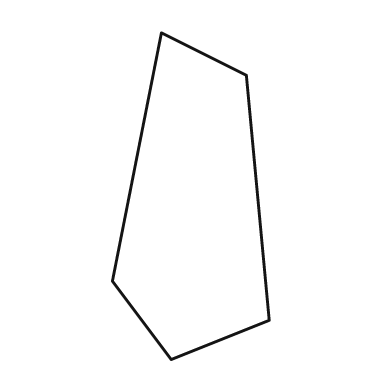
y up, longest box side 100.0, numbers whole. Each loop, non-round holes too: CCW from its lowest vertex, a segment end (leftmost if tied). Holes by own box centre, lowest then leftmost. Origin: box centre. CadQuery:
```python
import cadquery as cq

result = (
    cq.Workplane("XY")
    .moveTo(-6.0, -50.0)
    .lineTo(24.0, -38.0)
    .lineTo(17.0, 37.0)
    .lineTo(-9.0, 50.0)
    .lineTo(-24.0, -26.0)
    .close()
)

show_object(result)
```